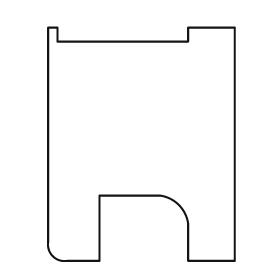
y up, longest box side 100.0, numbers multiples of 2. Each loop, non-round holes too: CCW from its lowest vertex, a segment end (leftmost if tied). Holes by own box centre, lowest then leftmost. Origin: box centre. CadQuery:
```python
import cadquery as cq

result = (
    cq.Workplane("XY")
    .moveTo(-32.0, -50.0)
    .lineTo(-18.0, -50.0)
    .lineTo(-18.0, -22.0)
    .lineTo(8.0, -22.0)
    .threePointArc((16.0, -26.0), (20.0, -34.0))
    .lineTo(20.0, -50.0)
    .lineTo(40.0, -50.0)
    .lineTo(40.0, 50.0)
    .lineTo(20.0, 50.0)
    .lineTo(20.0, 44.0)
    .lineTo(-36.0, 44.0)
    .lineTo(-36.0, 50.0)
    .lineTo(-40.0, 50.0)
    .lineTo(-40.0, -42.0)
    .threePointArc((-38.0, -48.0), (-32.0, -50.0))
    .close()
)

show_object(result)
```